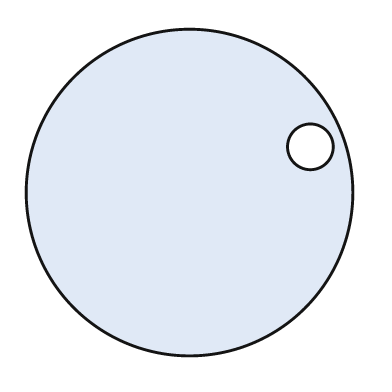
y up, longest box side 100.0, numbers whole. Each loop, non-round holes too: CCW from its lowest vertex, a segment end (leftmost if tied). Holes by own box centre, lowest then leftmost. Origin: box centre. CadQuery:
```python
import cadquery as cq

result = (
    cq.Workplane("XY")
    .moveTo(0.0, 0.0)
    .circle(50.0)
    .moveTo(37.0, 14.0)
    .circle(7.0)
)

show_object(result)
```